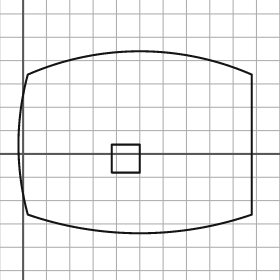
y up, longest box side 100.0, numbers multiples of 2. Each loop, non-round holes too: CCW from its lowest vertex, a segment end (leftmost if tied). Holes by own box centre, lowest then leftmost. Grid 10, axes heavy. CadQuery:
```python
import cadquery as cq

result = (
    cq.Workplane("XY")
    .moveTo(2.0, -26.0)
    .threePointArc((50.0, -34.0), (98.0, -26.0))
    .lineTo(98.0, 34.0)
    .threePointArc((50.0, 44.0), (2.0, 34.0))
    .threePointArc((-2.0, 4.0), (2.0, -26.0))
    .close()
    .moveTo(38.0, -8.0)
    .lineTo(50.0, -8.0)
    .lineTo(50.0, 4.0)
    .lineTo(38.0, 4.0)
    .close()
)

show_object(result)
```